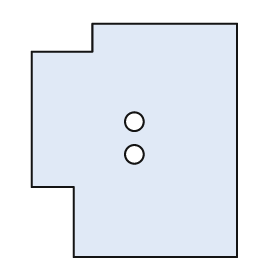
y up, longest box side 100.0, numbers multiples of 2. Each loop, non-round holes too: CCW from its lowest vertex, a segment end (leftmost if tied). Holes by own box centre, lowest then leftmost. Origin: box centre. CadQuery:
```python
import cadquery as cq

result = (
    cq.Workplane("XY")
    .moveTo(-26.0, -50.0)
    .lineTo(44.0, -50.0)
    .lineTo(44.0, 50.0)
    .lineTo(-18.0, 50.0)
    .lineTo(-18.0, 38.0)
    .lineTo(-44.0, 38.0)
    .lineTo(-44.0, -20.0)
    .lineTo(-26.0, -20.0)
    .close()
    .moveTo(0.0, -6.0)
    .circle(4.0)
    .moveTo(0.0, 8.0)
    .circle(4.0)
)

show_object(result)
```